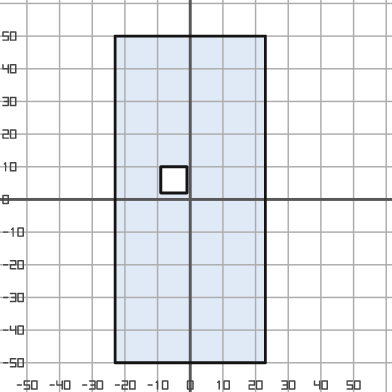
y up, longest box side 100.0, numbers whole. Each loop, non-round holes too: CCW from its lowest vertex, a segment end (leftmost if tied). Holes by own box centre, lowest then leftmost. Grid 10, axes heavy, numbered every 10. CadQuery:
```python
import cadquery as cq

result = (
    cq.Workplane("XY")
    .moveTo(-23.0, -50.0)
    .lineTo(23.0, -50.0)
    .lineTo(23.0, 50.0)
    .lineTo(-23.0, 50.0)
    .close()
    .moveTo(-9.0, 2.0)
    .lineTo(-1.0, 2.0)
    .lineTo(-1.0, 10.0)
    .lineTo(-9.0, 10.0)
    .close()
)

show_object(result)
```